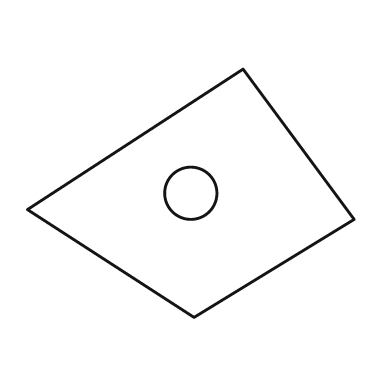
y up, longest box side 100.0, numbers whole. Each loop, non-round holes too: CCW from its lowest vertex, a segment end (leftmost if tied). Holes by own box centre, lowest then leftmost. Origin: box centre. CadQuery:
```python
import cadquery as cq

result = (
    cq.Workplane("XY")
    .moveTo(1.0, -38.0)
    .lineTo(50.0, -8.0)
    .lineTo(16.0, 38.0)
    .lineTo(-50.0, -5.0)
    .close()
    .moveTo(0.0, 0.0)
    .circle(8.0)
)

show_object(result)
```